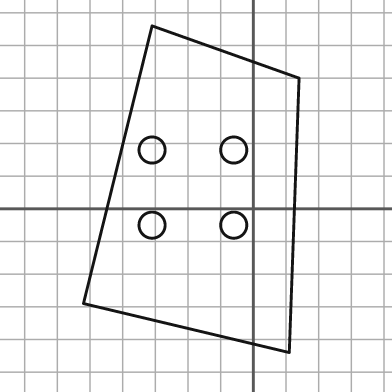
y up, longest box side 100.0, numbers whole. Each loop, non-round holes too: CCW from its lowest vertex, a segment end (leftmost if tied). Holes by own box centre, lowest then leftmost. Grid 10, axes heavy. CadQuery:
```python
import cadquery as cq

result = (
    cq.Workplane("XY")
    .moveTo(11.0, -44.0)
    .lineTo(14.0, 40.0)
    .lineTo(-31.0, 56.0)
    .lineTo(-52.0, -29.0)
    .close()
    .moveTo(-31.0, -5.0)
    .circle(4.0)
    .moveTo(-6.0, -5.0)
    .circle(4.0)
    .moveTo(-31.0, 18.0)
    .circle(4.0)
    .moveTo(-6.0, 18.0)
    .circle(4.0)
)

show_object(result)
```